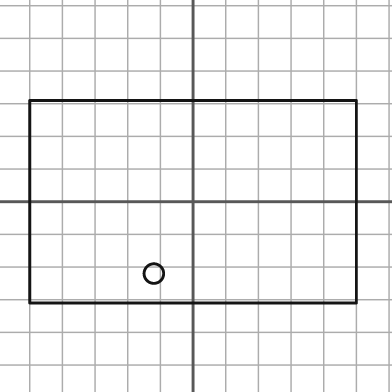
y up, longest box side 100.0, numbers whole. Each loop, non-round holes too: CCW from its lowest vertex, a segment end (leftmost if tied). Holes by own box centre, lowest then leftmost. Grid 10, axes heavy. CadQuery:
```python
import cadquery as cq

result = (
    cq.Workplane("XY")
    .moveTo(-50.0, -31.0)
    .lineTo(50.0, -31.0)
    .lineTo(50.0, 31.0)
    .lineTo(-50.0, 31.0)
    .close()
    .moveTo(-12.0, -22.0)
    .circle(3.0)
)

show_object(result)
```